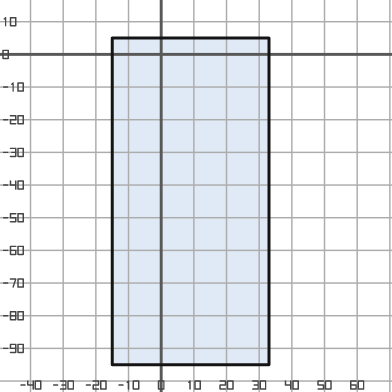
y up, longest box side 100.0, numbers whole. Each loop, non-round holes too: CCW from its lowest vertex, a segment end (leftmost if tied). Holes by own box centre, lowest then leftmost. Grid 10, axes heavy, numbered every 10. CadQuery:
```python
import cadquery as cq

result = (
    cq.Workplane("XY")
    .moveTo(-15.0, -95.0)
    .lineTo(33.0, -95.0)
    .lineTo(33.0, 5.0)
    .lineTo(-15.0, 5.0)
    .close()
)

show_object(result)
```